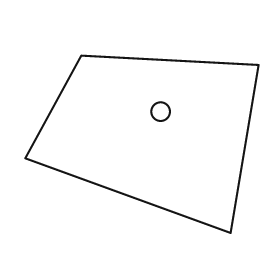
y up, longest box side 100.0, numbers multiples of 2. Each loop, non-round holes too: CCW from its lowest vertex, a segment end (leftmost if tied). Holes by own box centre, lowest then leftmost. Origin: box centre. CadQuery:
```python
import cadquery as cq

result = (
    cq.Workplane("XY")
    .moveTo(38.0, -38.0)
    .lineTo(50.0, 34.0)
    .lineTo(-26.0, 38.0)
    .lineTo(-50.0, -6.0)
    .close()
    .moveTo(8.0, 14.0)
    .circle(4.0)
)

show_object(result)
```